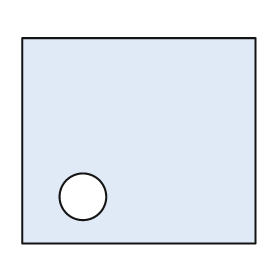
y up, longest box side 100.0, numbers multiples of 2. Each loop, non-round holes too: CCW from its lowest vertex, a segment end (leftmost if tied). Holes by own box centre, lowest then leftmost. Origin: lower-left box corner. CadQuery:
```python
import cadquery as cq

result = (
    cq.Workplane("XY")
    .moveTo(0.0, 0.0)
    .lineTo(100.0, 0.0)
    .lineTo(100.0, 88.0)
    .lineTo(0.0, 88.0)
    .close()
    .moveTo(26.0, 20.0)
    .circle(10.0)
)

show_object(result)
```